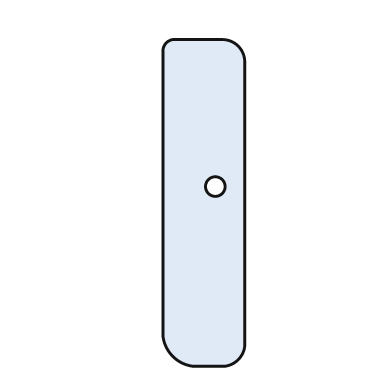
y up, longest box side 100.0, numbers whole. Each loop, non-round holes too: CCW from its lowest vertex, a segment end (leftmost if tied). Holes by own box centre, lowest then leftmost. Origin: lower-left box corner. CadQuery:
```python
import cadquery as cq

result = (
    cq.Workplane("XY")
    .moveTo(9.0, 0.0)
    .lineTo(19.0, 0.0)
    .threePointArc((23.0, 2.0), (25.0, 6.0))
    .lineTo(25.0, 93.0)
    .threePointArc((23.0, 98.0), (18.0, 100.0))
    .lineTo(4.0, 100.0)
    .threePointArc((1.0, 99.0), (0.0, 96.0))
    .lineTo(0.0, 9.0)
    .threePointArc((3.0, 3.0), (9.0, 0.0))
    .close()
    .moveTo(16.0, 55.0)
    .circle(3.0)
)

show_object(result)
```